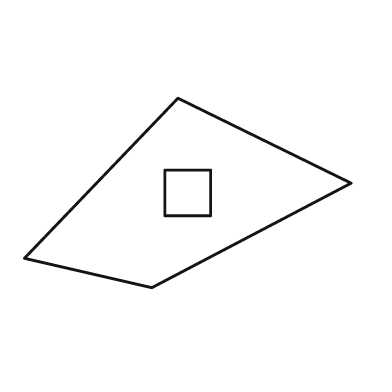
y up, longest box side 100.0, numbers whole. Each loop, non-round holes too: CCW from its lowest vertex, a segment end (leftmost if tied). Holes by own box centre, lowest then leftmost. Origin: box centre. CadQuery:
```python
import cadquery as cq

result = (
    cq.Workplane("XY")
    .moveTo(-11.0, -29.0)
    .lineTo(50.0, 3.0)
    .lineTo(-3.0, 29.0)
    .lineTo(-50.0, -20.0)
    .close()
    .moveTo(-7.0, -7.0)
    .lineTo(7.0, -7.0)
    .lineTo(7.0, 7.0)
    .lineTo(-7.0, 7.0)
    .close()
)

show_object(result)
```